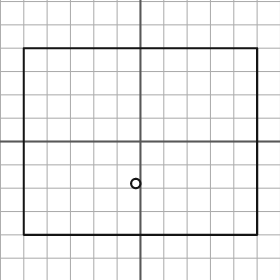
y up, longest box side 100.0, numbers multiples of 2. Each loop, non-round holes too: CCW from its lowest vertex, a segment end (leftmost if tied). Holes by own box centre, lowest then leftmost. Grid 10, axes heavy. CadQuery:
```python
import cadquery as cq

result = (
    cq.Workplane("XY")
    .moveTo(-50.0, -40.0)
    .lineTo(50.0, -40.0)
    .lineTo(50.0, 40.0)
    .lineTo(-50.0, 40.0)
    .close()
    .moveTo(-2.0, -18.0)
    .circle(2.0)
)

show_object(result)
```